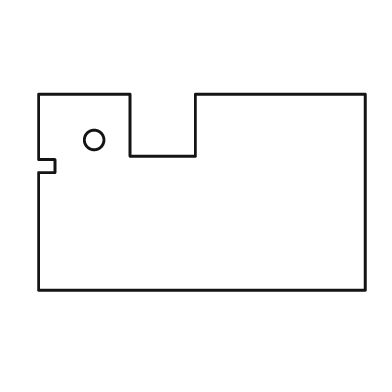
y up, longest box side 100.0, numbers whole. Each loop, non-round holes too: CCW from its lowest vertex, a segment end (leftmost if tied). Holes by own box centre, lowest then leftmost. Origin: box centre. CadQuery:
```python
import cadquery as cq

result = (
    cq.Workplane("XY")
    .moveTo(-50.0, -30.0)
    .lineTo(50.0, -30.0)
    .lineTo(50.0, 30.0)
    .lineTo(-2.0, 30.0)
    .lineTo(-2.0, 11.0)
    .lineTo(-22.0, 11.0)
    .lineTo(-22.0, 30.0)
    .lineTo(-50.0, 30.0)
    .lineTo(-50.0, 10.0)
    .lineTo(-45.0, 10.0)
    .lineTo(-45.0, 6.0)
    .lineTo(-50.0, 6.0)
    .close()
    .moveTo(-33.0, 16.0)
    .circle(3.0)
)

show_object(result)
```